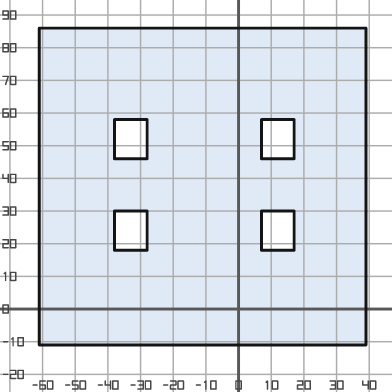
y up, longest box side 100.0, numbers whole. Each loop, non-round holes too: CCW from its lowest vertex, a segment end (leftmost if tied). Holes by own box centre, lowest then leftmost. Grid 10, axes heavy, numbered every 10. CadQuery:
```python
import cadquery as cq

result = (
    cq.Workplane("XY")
    .moveTo(-61.0, -11.0)
    .lineTo(39.0, -11.0)
    .lineTo(39.0, 86.0)
    .lineTo(-61.0, 86.0)
    .close()
    .moveTo(-38.0, 18.0)
    .lineTo(-28.0, 18.0)
    .lineTo(-28.0, 30.0)
    .lineTo(-38.0, 30.0)
    .close()
    .moveTo(7.0, 18.0)
    .lineTo(17.0, 18.0)
    .lineTo(17.0, 30.0)
    .lineTo(7.0, 30.0)
    .close()
    .moveTo(-38.0, 46.0)
    .lineTo(-28.0, 46.0)
    .lineTo(-28.0, 58.0)
    .lineTo(-38.0, 58.0)
    .close()
    .moveTo(7.0, 46.0)
    .lineTo(17.0, 46.0)
    .lineTo(17.0, 58.0)
    .lineTo(7.0, 58.0)
    .close()
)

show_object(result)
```